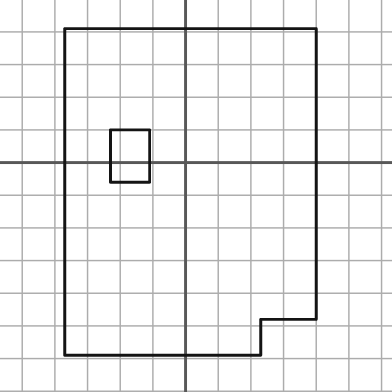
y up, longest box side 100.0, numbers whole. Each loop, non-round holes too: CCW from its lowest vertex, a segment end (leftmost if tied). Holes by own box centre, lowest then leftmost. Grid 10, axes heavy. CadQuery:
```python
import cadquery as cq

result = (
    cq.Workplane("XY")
    .moveTo(-37.0, -59.0)
    .lineTo(23.0, -59.0)
    .lineTo(23.0, -48.0)
    .lineTo(40.0, -48.0)
    .lineTo(40.0, 41.0)
    .lineTo(-37.0, 41.0)
    .close()
    .moveTo(-23.0, -6.0)
    .lineTo(-11.0, -6.0)
    .lineTo(-11.0, 10.0)
    .lineTo(-23.0, 10.0)
    .close()
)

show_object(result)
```